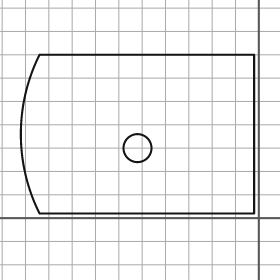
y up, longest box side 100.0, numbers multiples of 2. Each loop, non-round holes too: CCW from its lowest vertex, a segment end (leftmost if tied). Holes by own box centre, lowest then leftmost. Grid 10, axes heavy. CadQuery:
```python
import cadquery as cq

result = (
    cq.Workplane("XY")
    .moveTo(-94.0, 2.0)
    .lineTo(-2.0, 2.0)
    .lineTo(-2.0, 70.0)
    .lineTo(-94.0, 70.0)
    .threePointArc((-102.0, 36.0), (-94.0, 2.0))
    .close()
    .moveTo(-52.0, 30.0)
    .circle(6.0)
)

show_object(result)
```